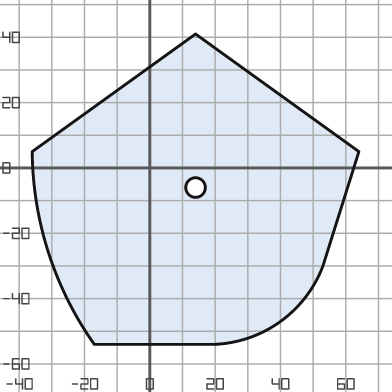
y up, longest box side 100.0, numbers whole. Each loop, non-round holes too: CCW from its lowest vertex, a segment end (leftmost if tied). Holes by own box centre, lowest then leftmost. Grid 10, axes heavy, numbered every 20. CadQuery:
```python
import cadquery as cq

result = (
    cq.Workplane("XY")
    .moveTo(-17.0, -54.0)
    .lineTo(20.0, -54.0)
    .threePointArc((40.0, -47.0), (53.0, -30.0))
    .lineTo(64.0, 5.0)
    .lineTo(14.0, 41.0)
    .lineTo(-36.0, 5.0)
    .threePointArc((-31.0, -26.0), (-17.0, -54.0))
    .close()
    .moveTo(14.0, -6.0)
    .circle(3.0)
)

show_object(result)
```